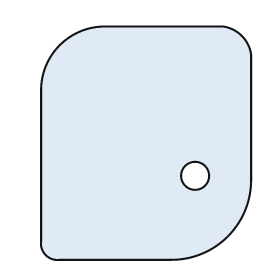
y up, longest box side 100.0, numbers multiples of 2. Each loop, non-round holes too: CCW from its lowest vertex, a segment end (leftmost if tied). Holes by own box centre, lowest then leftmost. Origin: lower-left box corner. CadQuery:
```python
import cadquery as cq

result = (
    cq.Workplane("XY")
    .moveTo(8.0, 0.0)
    .lineTo(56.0, 0.0)
    .threePointArc((80.0, 10.0), (90.0, 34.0))
    .lineTo(90.0, 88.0)
    .threePointArc((86.0, 96.0), (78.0, 100.0))
    .lineTo(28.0, 100.0)
    .threePointArc((8.0, 92.0), (0.0, 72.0))
    .lineTo(0.0, 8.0)
    .threePointArc((2.0, 2.0), (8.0, 0.0))
    .close()
    .moveTo(66.0, 36.0)
    .circle(6.0)
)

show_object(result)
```